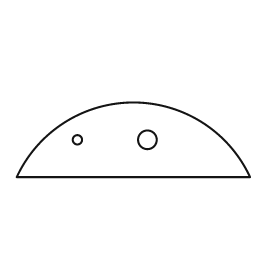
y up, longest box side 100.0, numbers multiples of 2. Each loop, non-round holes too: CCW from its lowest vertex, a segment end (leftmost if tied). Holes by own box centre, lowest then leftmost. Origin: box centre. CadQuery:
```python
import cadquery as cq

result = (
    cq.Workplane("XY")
    .moveTo(-50.0, -16.0)
    .lineTo(50.0, -16.0)
    .threePointArc((0.0, 16.0), (-50.0, -16.0))
    .close()
    .moveTo(-24.0, 0.0)
    .circle(2.0)
    .moveTo(6.0, 0.0)
    .circle(4.0)
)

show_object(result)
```